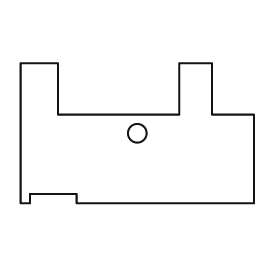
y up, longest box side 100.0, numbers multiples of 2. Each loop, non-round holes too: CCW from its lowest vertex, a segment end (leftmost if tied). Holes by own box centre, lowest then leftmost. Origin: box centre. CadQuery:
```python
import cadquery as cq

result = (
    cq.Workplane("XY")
    .moveTo(-50.0, -30.0)
    .lineTo(-46.0, -30.0)
    .lineTo(-46.0, -26.0)
    .lineTo(-26.0, -26.0)
    .lineTo(-26.0, -30.0)
    .lineTo(50.0, -30.0)
    .lineTo(50.0, 8.0)
    .lineTo(32.0, 8.0)
    .lineTo(32.0, 30.0)
    .lineTo(18.0, 30.0)
    .lineTo(18.0, 8.0)
    .lineTo(-34.0, 8.0)
    .lineTo(-34.0, 30.0)
    .lineTo(-50.0, 30.0)
    .close()
    .moveTo(0.0, 0.0)
    .circle(4.0)
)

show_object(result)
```